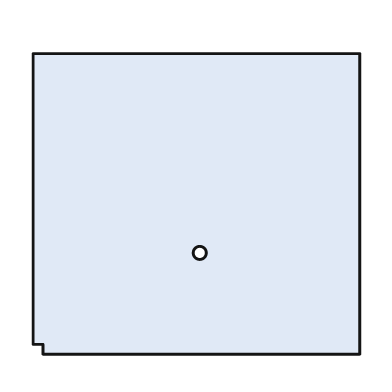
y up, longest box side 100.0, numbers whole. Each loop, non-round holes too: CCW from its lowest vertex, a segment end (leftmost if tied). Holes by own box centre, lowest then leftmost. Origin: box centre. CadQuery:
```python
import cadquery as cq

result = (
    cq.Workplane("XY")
    .moveTo(-47.0, -46.0)
    .lineTo(50.0, -46.0)
    .lineTo(50.0, 46.0)
    .lineTo(-50.0, 46.0)
    .lineTo(-50.0, -43.0)
    .lineTo(-47.0, -43.0)
    .close()
    .moveTo(1.0, -15.0)
    .circle(2.0)
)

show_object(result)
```